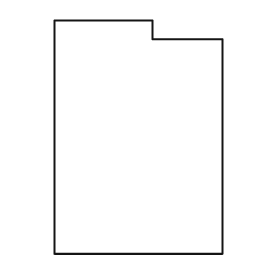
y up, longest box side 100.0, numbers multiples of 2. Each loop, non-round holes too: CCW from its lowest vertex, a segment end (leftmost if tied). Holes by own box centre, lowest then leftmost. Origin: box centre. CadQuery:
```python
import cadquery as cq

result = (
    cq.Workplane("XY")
    .moveTo(-36.0, -50.0)
    .lineTo(36.0, -50.0)
    .lineTo(36.0, 42.0)
    .lineTo(6.0, 42.0)
    .lineTo(6.0, 50.0)
    .lineTo(-36.0, 50.0)
    .close()
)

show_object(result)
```